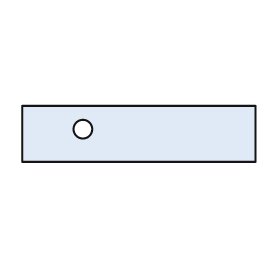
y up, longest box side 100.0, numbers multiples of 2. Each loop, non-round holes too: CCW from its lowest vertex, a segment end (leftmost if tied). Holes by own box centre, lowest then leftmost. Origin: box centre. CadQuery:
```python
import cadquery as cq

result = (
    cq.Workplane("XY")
    .moveTo(-50.0, -12.0)
    .lineTo(50.0, -12.0)
    .lineTo(50.0, 12.0)
    .lineTo(-50.0, 12.0)
    .close()
    .moveTo(-24.0, 2.0)
    .circle(4.0)
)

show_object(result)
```